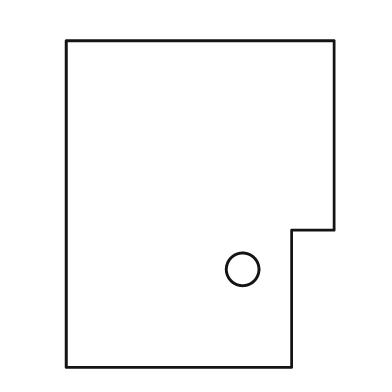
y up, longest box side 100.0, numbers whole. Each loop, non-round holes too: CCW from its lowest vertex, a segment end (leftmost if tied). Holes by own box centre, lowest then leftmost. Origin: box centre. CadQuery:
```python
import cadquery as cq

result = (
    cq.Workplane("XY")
    .moveTo(-41.0, -50.0)
    .lineTo(28.0, -50.0)
    .lineTo(28.0, -8.0)
    .lineTo(41.0, -8.0)
    .lineTo(41.0, 50.0)
    .lineTo(-41.0, 50.0)
    .close()
    .moveTo(13.0, -20.0)
    .circle(5.0)
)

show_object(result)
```